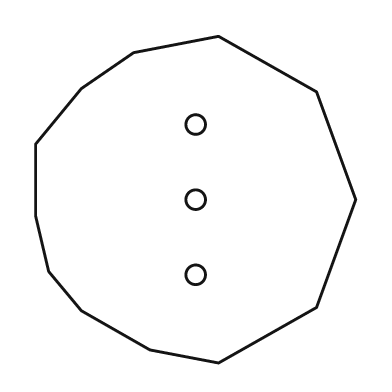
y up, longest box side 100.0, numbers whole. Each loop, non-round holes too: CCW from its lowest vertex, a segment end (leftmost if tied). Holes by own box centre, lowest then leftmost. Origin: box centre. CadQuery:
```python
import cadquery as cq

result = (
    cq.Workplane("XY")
    .moveTo(7.0, -50.0)
    .lineTo(37.0, -33.0)
    .lineTo(49.0, 0.0)
    .lineTo(37.0, 33.0)
    .lineTo(7.0, 50.0)
    .lineTo(-19.0, 45.0)
    .lineTo(-35.0, 34.0)
    .lineTo(-49.0, 17.0)
    .lineTo(-49.0, -5.0)
    .lineTo(-45.0, -22.0)
    .lineTo(-35.0, -34.0)
    .lineTo(-14.0, -46.0)
    .close()
    .moveTo(0.0, -23.0)
    .circle(3.0)
    .moveTo(0.0, 0.0)
    .circle(3.0)
    .moveTo(0.0, 23.0)
    .circle(3.0)
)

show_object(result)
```